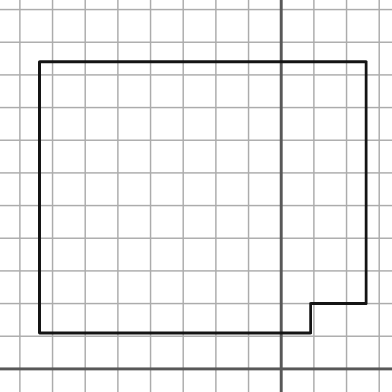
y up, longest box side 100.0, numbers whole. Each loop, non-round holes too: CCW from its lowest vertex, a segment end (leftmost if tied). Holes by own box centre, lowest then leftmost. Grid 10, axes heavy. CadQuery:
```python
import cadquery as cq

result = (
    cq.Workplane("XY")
    .moveTo(-74.0, 11.0)
    .lineTo(9.0, 11.0)
    .lineTo(9.0, 20.0)
    .lineTo(26.0, 20.0)
    .lineTo(26.0, 94.0)
    .lineTo(-74.0, 94.0)
    .close()
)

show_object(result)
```